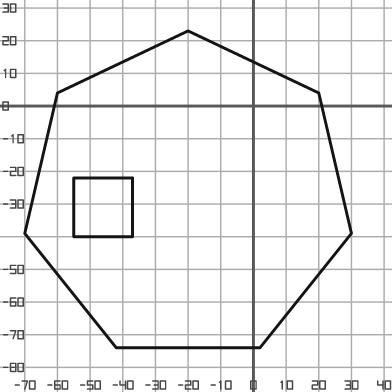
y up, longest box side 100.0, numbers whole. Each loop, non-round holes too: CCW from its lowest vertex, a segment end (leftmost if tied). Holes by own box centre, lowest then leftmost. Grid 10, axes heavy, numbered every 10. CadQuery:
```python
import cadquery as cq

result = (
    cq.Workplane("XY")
    .moveTo(-42.0, -74.0)
    .lineTo(2.0, -74.0)
    .lineTo(30.0, -39.0)
    .lineTo(20.0, 4.0)
    .lineTo(-20.0, 23.0)
    .lineTo(-60.0, 4.0)
    .lineTo(-70.0, -39.0)
    .close()
    .moveTo(-55.0, -40.0)
    .lineTo(-37.0, -40.0)
    .lineTo(-37.0, -22.0)
    .lineTo(-55.0, -22.0)
    .close()
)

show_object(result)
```